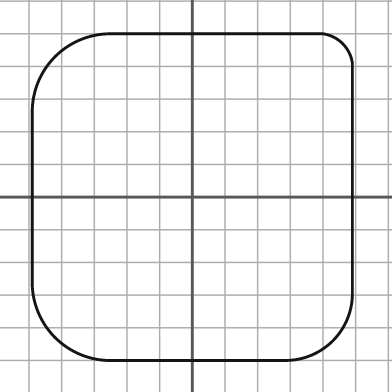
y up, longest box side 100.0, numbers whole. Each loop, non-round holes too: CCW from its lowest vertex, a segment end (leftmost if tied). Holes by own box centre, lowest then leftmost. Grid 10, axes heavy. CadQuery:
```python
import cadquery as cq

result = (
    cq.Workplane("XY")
    .moveTo(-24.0, -50.0)
    .lineTo(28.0, -50.0)
    .threePointArc((43.0, -44.0), (49.0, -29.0))
    .lineTo(49.0, 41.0)
    .threePointArc((46.0, 47.0), (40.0, 50.0))
    .lineTo(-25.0, 50.0)
    .threePointArc((-42.0, 43.0), (-49.0, 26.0))
    .lineTo(-49.0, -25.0)
    .threePointArc((-42.0, -43.0), (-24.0, -50.0))
    .close()
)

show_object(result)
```